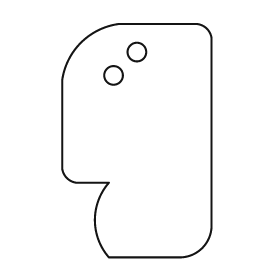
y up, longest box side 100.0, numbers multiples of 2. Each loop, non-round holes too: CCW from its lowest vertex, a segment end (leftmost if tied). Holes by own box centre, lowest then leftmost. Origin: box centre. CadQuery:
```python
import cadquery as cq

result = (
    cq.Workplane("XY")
    .moveTo(-12.0, -50.0)
    .lineTo(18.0, -50.0)
    .threePointArc((28.0, -46.0), (32.0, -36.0))
    .lineTo(32.0, 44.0)
    .threePointArc((30.0, 48.0), (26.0, 50.0))
    .lineTo(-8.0, 50.0)
    .threePointArc((-24.0, 42.0), (-32.0, 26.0))
    .lineTo(-32.0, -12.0)
    .threePointArc((-30.0, -16.0), (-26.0, -18.0))
    .lineTo(-12.0, -18.0)
    .threePointArc((-18.0, -34.0), (-12.0, -50.0))
    .close()
    .moveTo(-10.0, 28.0)
    .circle(4.0)
    .moveTo(0.0, 38.0)
    .circle(4.0)
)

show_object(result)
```